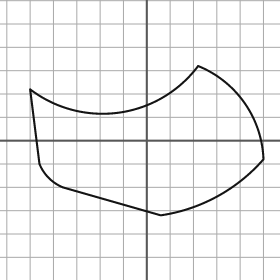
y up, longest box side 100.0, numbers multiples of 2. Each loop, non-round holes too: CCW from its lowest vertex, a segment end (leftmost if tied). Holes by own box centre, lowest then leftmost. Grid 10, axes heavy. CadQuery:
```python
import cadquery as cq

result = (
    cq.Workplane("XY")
    .moveTo(6.0, -32.0)
    .threePointArc((30.0, -24.0), (50.0, -8.0))
    .threePointArc((42.0, 16.0), (22.0, 32.0))
    .threePointArc((-12.0, 12.0), (-50.0, 22.0))
    .lineTo(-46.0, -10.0)
    .threePointArc((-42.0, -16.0), (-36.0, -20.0))
    .close()
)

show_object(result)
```